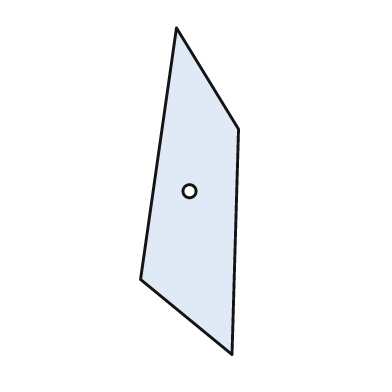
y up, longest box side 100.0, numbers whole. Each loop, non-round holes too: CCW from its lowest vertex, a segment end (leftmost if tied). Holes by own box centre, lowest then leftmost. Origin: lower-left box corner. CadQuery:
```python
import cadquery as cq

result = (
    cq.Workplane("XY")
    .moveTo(28.0, 0.0)
    .lineTo(30.0, 69.0)
    .lineTo(11.0, 100.0)
    .lineTo(0.0, 23.0)
    .close()
    .moveTo(15.0, 50.0)
    .circle(2.0)
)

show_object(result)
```